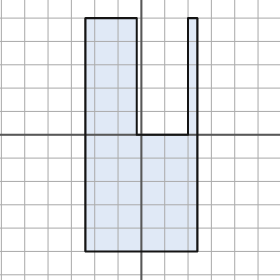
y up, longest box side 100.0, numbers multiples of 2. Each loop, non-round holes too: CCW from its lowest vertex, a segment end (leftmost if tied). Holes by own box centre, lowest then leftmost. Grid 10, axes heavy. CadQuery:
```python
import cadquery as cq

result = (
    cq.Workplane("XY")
    .moveTo(-24.0, -50.0)
    .lineTo(24.0, -50.0)
    .lineTo(24.0, 50.0)
    .lineTo(20.0, 50.0)
    .lineTo(20.0, 0.0)
    .lineTo(-2.0, 0.0)
    .lineTo(-2.0, 50.0)
    .lineTo(-24.0, 50.0)
    .close()
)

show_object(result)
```